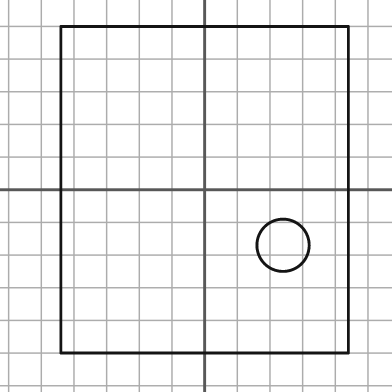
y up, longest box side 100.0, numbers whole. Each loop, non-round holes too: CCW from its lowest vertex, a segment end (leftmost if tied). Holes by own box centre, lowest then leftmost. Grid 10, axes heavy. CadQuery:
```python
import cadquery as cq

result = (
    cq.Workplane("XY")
    .moveTo(-44.0, -50.0)
    .lineTo(44.0, -50.0)
    .lineTo(44.0, 50.0)
    .lineTo(-44.0, 50.0)
    .close()
    .moveTo(24.0, -17.0)
    .circle(8.0)
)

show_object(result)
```